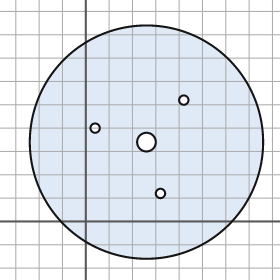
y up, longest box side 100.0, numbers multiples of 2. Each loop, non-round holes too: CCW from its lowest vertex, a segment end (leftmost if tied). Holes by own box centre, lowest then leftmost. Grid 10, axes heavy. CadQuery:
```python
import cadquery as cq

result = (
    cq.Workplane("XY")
    .moveTo(26.0, 34.0)
    .circle(50.0)
    .moveTo(32.0, 12.0)
    .circle(2.0)
    .moveTo(26.0, 34.0)
    .circle(4.0)
    .moveTo(4.0, 40.0)
    .circle(2.0)
    .moveTo(42.0, 52.0)
    .circle(2.0)
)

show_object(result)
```